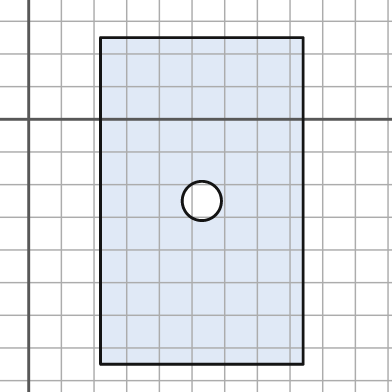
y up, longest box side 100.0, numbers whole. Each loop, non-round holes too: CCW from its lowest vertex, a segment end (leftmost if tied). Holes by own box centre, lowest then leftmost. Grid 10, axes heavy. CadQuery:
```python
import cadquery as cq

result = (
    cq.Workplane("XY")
    .moveTo(22.0, -75.0)
    .lineTo(84.0, -75.0)
    .lineTo(84.0, 25.0)
    .lineTo(22.0, 25.0)
    .close()
    .moveTo(53.0, -25.0)
    .circle(6.0)
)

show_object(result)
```